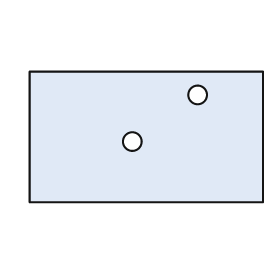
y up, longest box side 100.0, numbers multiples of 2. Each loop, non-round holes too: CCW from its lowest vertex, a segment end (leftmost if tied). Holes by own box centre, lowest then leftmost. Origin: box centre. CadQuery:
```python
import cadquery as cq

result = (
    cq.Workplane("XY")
    .moveTo(-50.0, -28.0)
    .lineTo(50.0, -28.0)
    .lineTo(50.0, 28.0)
    .lineTo(-50.0, 28.0)
    .close()
    .moveTo(-6.0, -2.0)
    .circle(4.0)
    .moveTo(22.0, 18.0)
    .circle(4.0)
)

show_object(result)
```